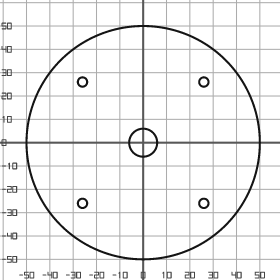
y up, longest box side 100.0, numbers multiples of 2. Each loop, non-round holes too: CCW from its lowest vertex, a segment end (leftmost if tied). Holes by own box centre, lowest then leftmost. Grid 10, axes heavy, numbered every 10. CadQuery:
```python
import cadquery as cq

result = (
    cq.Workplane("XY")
    .moveTo(0.0, 0.0)
    .circle(50.0)
    .moveTo(-26.0, -26.0)
    .circle(2.0)
    .moveTo(26.0, -26.0)
    .circle(2.0)
    .moveTo(0.0, 0.0)
    .circle(6.0)
    .moveTo(-26.0, 26.0)
    .circle(2.0)
    .moveTo(26.0, 26.0)
    .circle(2.0)
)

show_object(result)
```